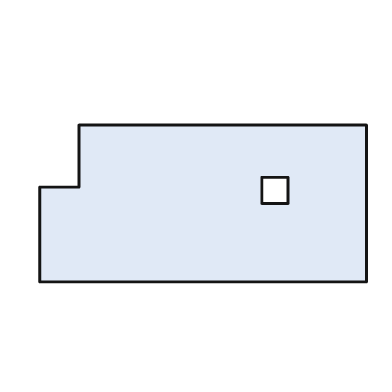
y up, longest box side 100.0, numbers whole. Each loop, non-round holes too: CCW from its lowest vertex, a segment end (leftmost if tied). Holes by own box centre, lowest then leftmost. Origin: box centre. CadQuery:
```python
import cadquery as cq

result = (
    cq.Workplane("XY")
    .moveTo(-50.0, -24.0)
    .lineTo(50.0, -24.0)
    .lineTo(50.0, 24.0)
    .lineTo(-38.0, 24.0)
    .lineTo(-38.0, 5.0)
    .lineTo(-50.0, 5.0)
    .close()
    .moveTo(18.0, 0.0)
    .lineTo(26.0, 0.0)
    .lineTo(26.0, 8.0)
    .lineTo(18.0, 8.0)
    .close()
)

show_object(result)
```